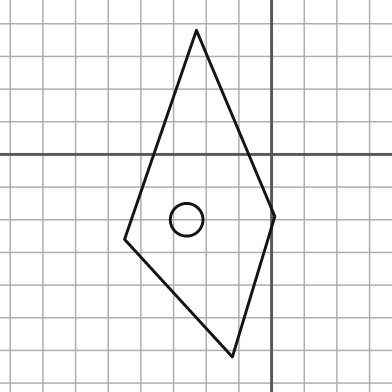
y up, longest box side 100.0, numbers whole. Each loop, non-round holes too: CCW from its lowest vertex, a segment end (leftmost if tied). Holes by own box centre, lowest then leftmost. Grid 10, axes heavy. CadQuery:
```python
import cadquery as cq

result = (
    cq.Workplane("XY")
    .moveTo(-12.0, -62.0)
    .lineTo(1.0, -19.0)
    .lineTo(-23.0, 38.0)
    .lineTo(-45.0, -26.0)
    .close()
    .moveTo(-26.0, -20.0)
    .circle(5.0)
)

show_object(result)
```